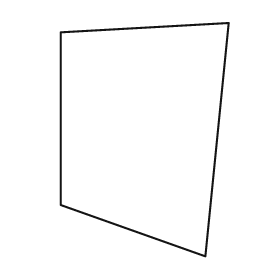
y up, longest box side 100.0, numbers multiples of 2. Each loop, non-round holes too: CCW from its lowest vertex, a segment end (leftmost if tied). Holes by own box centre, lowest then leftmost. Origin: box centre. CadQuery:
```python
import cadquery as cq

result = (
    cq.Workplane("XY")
    .moveTo(26.0, -50.0)
    .lineTo(36.0, 50.0)
    .lineTo(-36.0, 46.0)
    .lineTo(-36.0, -28.0)
    .close()
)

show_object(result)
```